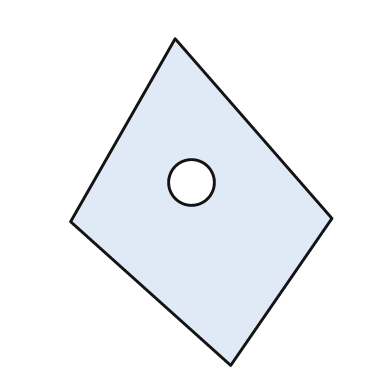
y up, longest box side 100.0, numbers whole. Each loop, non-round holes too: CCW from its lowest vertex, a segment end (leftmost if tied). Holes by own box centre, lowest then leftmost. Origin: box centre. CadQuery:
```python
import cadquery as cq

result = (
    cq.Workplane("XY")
    .moveTo(9.0, -50.0)
    .lineTo(40.0, -5.0)
    .lineTo(-8.0, 50.0)
    .lineTo(-40.0, -6.0)
    .close()
    .moveTo(-3.0, 6.0)
    .circle(7.0)
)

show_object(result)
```